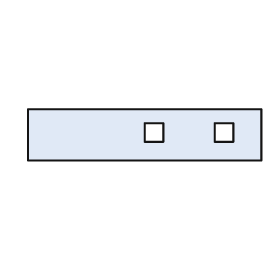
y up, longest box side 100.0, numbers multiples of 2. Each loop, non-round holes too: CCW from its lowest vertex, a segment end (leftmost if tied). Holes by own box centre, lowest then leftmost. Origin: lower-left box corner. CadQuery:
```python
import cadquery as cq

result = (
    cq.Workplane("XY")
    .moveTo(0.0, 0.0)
    .lineTo(100.0, 0.0)
    .lineTo(100.0, 22.0)
    .lineTo(0.0, 22.0)
    .close()
    .moveTo(50.0, 8.0)
    .lineTo(58.0, 8.0)
    .lineTo(58.0, 16.0)
    .lineTo(50.0, 16.0)
    .close()
    .moveTo(80.0, 8.0)
    .lineTo(88.0, 8.0)
    .lineTo(88.0, 16.0)
    .lineTo(80.0, 16.0)
    .close()
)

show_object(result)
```